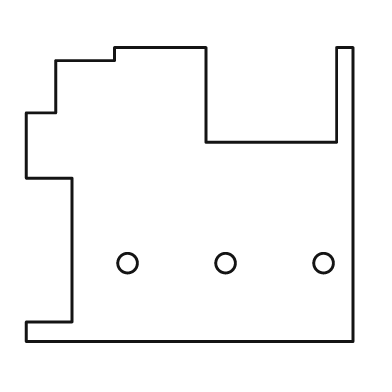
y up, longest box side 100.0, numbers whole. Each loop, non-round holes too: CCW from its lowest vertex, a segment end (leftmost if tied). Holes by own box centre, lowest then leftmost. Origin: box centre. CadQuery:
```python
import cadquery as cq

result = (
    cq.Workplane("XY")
    .moveTo(-50.0, -45.0)
    .lineTo(50.0, -45.0)
    .lineTo(50.0, 45.0)
    .lineTo(45.0, 45.0)
    .lineTo(45.0, 16.0)
    .lineTo(5.0, 16.0)
    .lineTo(5.0, 45.0)
    .lineTo(-23.0, 45.0)
    .lineTo(-23.0, 41.0)
    .lineTo(-41.0, 41.0)
    .lineTo(-41.0, 25.0)
    .lineTo(-50.0, 25.0)
    .lineTo(-50.0, 5.0)
    .lineTo(-36.0, 5.0)
    .lineTo(-36.0, -39.0)
    .lineTo(-50.0, -39.0)
    .close()
    .moveTo(-19.0, -21.0)
    .circle(3.0)
    .moveTo(11.0, -21.0)
    .circle(3.0)
    .moveTo(41.0, -21.0)
    .circle(3.0)
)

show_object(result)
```